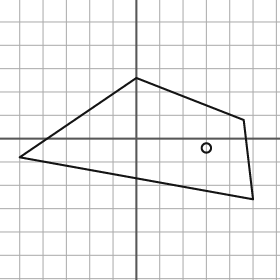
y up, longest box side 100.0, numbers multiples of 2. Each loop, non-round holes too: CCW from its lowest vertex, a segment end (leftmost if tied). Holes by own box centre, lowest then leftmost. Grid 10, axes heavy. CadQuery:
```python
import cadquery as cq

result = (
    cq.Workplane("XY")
    .moveTo(50.0, -26.0)
    .lineTo(46.0, 8.0)
    .lineTo(0.0, 26.0)
    .lineTo(-50.0, -8.0)
    .close()
    .moveTo(30.0, -4.0)
    .circle(2.0)
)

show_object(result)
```